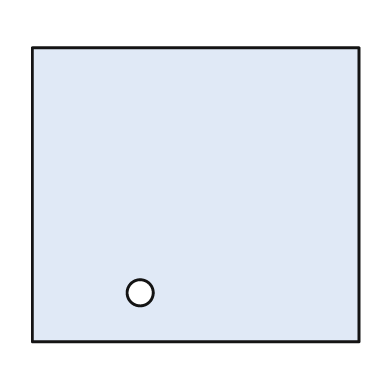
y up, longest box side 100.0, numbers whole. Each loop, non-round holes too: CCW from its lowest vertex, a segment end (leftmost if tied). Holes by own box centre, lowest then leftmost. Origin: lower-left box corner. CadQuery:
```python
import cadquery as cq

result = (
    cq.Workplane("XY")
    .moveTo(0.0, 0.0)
    .lineTo(100.0, 0.0)
    .lineTo(100.0, 90.0)
    .lineTo(0.0, 90.0)
    .close()
    .moveTo(33.0, 15.0)
    .circle(4.0)
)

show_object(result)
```